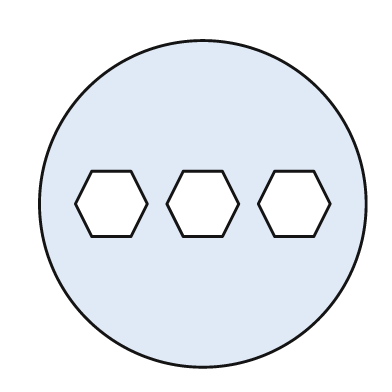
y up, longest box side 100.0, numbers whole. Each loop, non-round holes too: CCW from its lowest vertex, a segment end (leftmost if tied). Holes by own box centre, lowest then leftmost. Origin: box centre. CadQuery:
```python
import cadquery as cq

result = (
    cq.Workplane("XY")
    .moveTo(0.0, 0.0)
    .circle(50.0)
    .moveTo(-34.0, -10.0)
    .lineTo(-22.0, -10.0)
    .lineTo(-17.0, 0.0)
    .lineTo(-22.0, 10.0)
    .lineTo(-34.0, 10.0)
    .lineTo(-39.0, 0.0)
    .close()
    .moveTo(-6.0, -10.0)
    .lineTo(6.0, -10.0)
    .lineTo(11.0, 0.0)
    .lineTo(6.0, 10.0)
    .lineTo(-6.0, 10.0)
    .lineTo(-11.0, 0.0)
    .close()
    .moveTo(22.0, -10.0)
    .lineTo(34.0, -10.0)
    .lineTo(39.0, 0.0)
    .lineTo(34.0, 10.0)
    .lineTo(22.0, 10.0)
    .lineTo(17.0, 0.0)
    .close()
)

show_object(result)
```